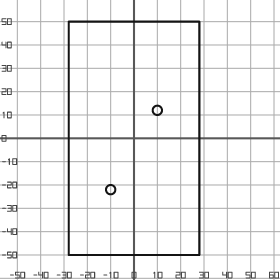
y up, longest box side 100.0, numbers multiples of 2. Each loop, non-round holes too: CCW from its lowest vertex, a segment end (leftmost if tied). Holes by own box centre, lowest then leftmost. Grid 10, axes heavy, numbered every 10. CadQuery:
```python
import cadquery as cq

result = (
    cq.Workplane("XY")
    .moveTo(-28.0, -50.0)
    .lineTo(28.0, -50.0)
    .lineTo(28.0, 50.0)
    .lineTo(-28.0, 50.0)
    .close()
    .moveTo(-10.0, -22.0)
    .circle(2.0)
    .moveTo(10.0, 12.0)
    .circle(2.0)
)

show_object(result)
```